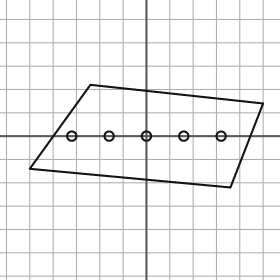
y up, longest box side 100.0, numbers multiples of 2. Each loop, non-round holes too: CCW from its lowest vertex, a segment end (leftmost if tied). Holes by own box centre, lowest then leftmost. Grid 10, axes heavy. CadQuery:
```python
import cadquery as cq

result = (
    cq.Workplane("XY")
    .moveTo(36.0, -22.0)
    .lineTo(50.0, 14.0)
    .lineTo(-24.0, 22.0)
    .lineTo(-50.0, -14.0)
    .close()
    .moveTo(-32.0, 0.0)
    .circle(2.0)
    .moveTo(-16.0, 0.0)
    .circle(2.0)
    .moveTo(0.0, 0.0)
    .circle(2.0)
    .moveTo(16.0, 0.0)
    .circle(2.0)
    .moveTo(32.0, 0.0)
    .circle(2.0)
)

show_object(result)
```